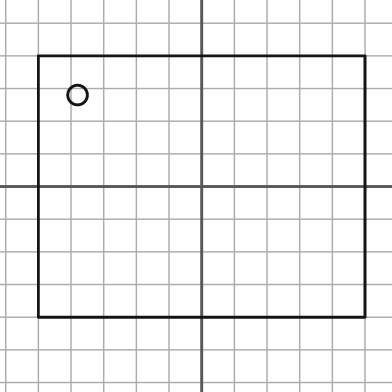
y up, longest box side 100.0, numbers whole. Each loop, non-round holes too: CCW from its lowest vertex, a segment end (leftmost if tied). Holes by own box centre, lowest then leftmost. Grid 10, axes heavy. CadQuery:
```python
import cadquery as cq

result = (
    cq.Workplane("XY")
    .moveTo(-50.0, -40.0)
    .lineTo(50.0, -40.0)
    .lineTo(50.0, 40.0)
    .lineTo(-50.0, 40.0)
    .close()
    .moveTo(-38.0, 28.0)
    .circle(3.0)
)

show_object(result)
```